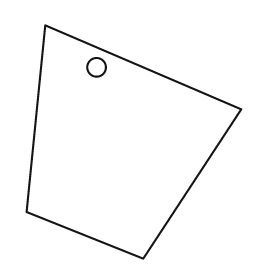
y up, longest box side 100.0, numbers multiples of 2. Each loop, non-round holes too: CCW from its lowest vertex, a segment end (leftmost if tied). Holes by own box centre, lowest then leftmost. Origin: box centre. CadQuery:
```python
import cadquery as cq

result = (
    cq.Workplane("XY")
    .moveTo(4.0, -50.0)
    .lineTo(46.0, 14.0)
    .lineTo(-38.0, 50.0)
    .lineTo(-46.0, -30.0)
    .close()
    .moveTo(-16.0, 32.0)
    .circle(4.0)
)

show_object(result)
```